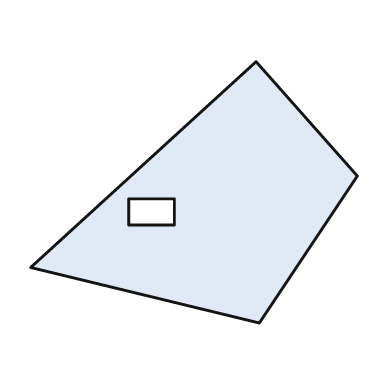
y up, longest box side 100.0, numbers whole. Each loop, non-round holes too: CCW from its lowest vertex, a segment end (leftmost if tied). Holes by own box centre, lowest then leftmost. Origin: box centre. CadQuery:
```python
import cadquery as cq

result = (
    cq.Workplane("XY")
    .moveTo(20.0, -40.0)
    .lineTo(50.0, 5.0)
    .lineTo(19.0, 40.0)
    .lineTo(-50.0, -23.0)
    .close()
    .moveTo(-20.0, -10.0)
    .lineTo(-6.0, -10.0)
    .lineTo(-6.0, -2.0)
    .lineTo(-20.0, -2.0)
    .close()
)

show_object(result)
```